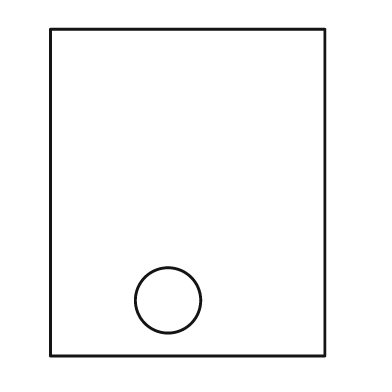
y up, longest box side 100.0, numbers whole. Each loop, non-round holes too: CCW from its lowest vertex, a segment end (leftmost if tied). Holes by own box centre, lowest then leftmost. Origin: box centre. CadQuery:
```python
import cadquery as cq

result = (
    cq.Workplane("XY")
    .moveTo(-42.0, -50.0)
    .lineTo(42.0, -50.0)
    .lineTo(42.0, 50.0)
    .lineTo(-42.0, 50.0)
    .close()
    .moveTo(-6.0, -33.0)
    .circle(10.0)
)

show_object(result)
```